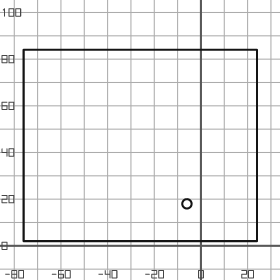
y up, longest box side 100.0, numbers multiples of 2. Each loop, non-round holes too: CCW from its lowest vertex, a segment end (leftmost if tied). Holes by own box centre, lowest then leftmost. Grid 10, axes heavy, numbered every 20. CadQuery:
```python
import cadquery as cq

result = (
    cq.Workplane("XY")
    .moveTo(-76.0, 2.0)
    .lineTo(24.0, 2.0)
    .lineTo(24.0, 84.0)
    .lineTo(-76.0, 84.0)
    .close()
    .moveTo(-6.0, 18.0)
    .circle(2.0)
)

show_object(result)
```